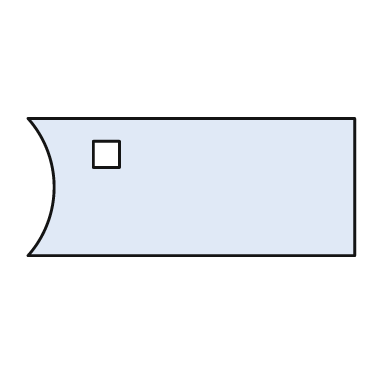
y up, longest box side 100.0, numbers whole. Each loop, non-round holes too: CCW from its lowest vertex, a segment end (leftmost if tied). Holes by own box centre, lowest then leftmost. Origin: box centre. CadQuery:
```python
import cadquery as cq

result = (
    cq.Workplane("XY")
    .moveTo(-50.0, -21.0)
    .lineTo(50.0, -21.0)
    .lineTo(50.0, 21.0)
    .lineTo(-50.0, 21.0)
    .threePointArc((-42.0, 0.0), (-50.0, -21.0))
    .close()
    .moveTo(-30.0, 6.0)
    .lineTo(-22.0, 6.0)
    .lineTo(-22.0, 14.0)
    .lineTo(-30.0, 14.0)
    .close()
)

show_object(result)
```